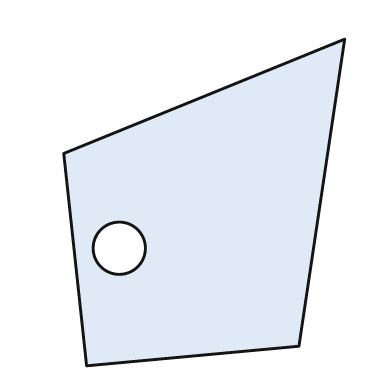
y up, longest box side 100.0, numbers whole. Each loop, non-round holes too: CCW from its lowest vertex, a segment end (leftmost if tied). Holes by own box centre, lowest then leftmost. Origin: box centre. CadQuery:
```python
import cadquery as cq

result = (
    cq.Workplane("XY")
    .moveTo(-36.0, -50.0)
    .lineTo(29.0, -44.0)
    .lineTo(43.0, 50.0)
    .lineTo(-43.0, 15.0)
    .close()
    .moveTo(-26.0, -14.0)
    .circle(8.0)
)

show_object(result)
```